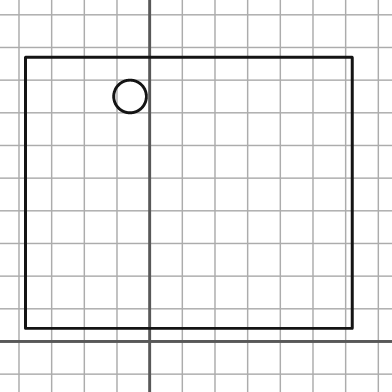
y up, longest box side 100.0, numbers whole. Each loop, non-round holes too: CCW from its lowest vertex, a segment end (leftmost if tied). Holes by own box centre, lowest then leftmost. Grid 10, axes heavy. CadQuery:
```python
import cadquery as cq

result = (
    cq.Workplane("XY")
    .moveTo(-38.0, 4.0)
    .lineTo(62.0, 4.0)
    .lineTo(62.0, 87.0)
    .lineTo(-38.0, 87.0)
    .close()
    .moveTo(-6.0, 75.0)
    .circle(5.0)
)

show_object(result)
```